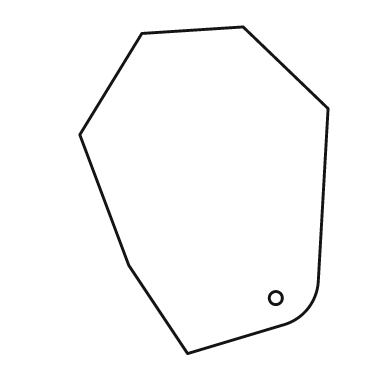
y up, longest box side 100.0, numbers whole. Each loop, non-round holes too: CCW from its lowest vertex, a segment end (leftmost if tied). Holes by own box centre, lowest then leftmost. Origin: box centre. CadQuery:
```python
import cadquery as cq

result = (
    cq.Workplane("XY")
    .moveTo(-5.0, -50.0)
    .lineTo(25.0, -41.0)
    .threePointArc((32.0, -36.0), (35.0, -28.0))
    .lineTo(38.0, 25.0)
    .lineTo(12.0, 50.0)
    .lineTo(-19.0, 48.0)
    .lineTo(-38.0, 17.0)
    .lineTo(-23.0, -23.0)
    .close()
    .moveTo(22.0, -33.0)
    .circle(2.0)
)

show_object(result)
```